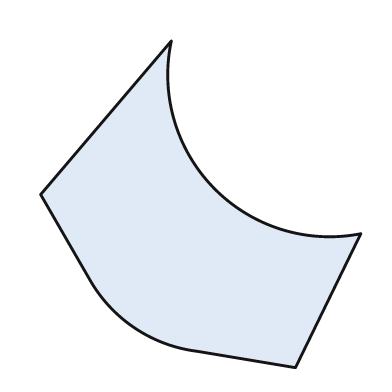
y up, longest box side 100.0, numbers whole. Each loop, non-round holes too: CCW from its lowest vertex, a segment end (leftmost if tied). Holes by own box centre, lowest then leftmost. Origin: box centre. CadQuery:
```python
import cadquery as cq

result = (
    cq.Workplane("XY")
    .moveTo(29.0, -50.0)
    .lineTo(49.0, -9.0)
    .threePointArc((4.0, 5.0), (-9.0, 50.0))
    .lineTo(-49.0, 3.0)
    .lineTo(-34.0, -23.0)
    .threePointArc((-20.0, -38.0), (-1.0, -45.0))
    .close()
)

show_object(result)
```